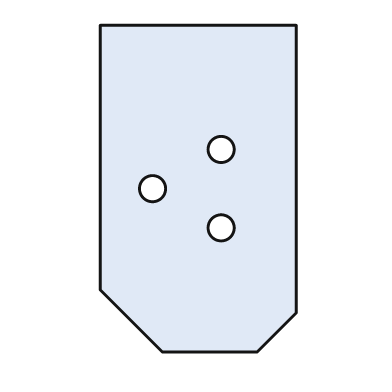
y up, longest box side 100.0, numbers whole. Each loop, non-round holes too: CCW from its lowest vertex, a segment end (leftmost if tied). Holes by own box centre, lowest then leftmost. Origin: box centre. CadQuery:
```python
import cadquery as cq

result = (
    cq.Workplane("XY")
    .moveTo(-11.0, -50.0)
    .lineTo(18.0, -50.0)
    .lineTo(30.0, -38.0)
    .lineTo(30.0, 50.0)
    .lineTo(-30.0, 50.0)
    .lineTo(-30.0, -31.0)
    .close()
    .moveTo(7.0, -12.0)
    .circle(4.0)
    .moveTo(-14.0, 0.0)
    .circle(4.0)
    .moveTo(7.0, 12.0)
    .circle(4.0)
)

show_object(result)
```